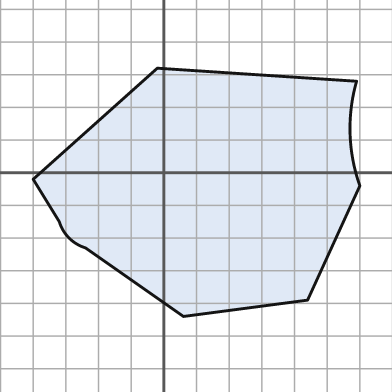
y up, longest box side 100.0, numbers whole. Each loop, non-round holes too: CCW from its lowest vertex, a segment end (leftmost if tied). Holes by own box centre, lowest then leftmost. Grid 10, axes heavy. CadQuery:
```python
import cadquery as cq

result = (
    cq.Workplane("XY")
    .moveTo(6.0, -44.0)
    .lineTo(44.0, -39.0)
    .lineTo(60.0, -4.0)
    .threePointArc((57.0, 12.0), (59.0, 28.0))
    .lineTo(-2.0, 32.0)
    .lineTo(-40.0, -2.0)
    .lineTo(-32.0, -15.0)
    .threePointArc((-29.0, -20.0), (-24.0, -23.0))
    .close()
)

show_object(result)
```